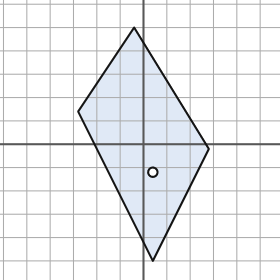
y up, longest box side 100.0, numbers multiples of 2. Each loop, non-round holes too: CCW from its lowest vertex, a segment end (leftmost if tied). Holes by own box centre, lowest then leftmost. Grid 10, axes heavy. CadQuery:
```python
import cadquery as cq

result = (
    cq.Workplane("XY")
    .moveTo(4.0, -50.0)
    .lineTo(28.0, -2.0)
    .lineTo(-4.0, 50.0)
    .lineTo(-28.0, 14.0)
    .close()
    .moveTo(4.0, -12.0)
    .circle(2.0)
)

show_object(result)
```